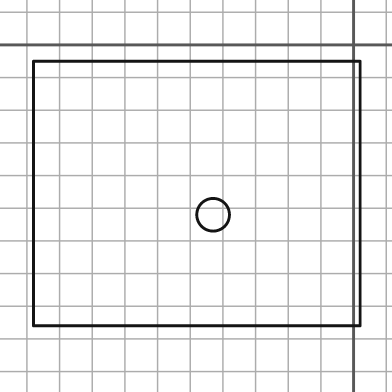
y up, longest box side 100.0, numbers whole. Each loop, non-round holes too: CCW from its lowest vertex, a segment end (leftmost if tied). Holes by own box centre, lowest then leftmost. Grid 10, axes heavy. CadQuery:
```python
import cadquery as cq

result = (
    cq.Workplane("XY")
    .moveTo(-98.0, -86.0)
    .lineTo(2.0, -86.0)
    .lineTo(2.0, -5.0)
    .lineTo(-98.0, -5.0)
    .close()
    .moveTo(-43.0, -52.0)
    .circle(5.0)
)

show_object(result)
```